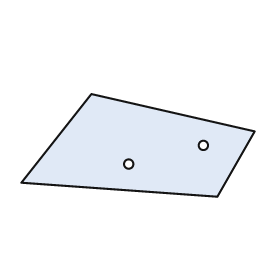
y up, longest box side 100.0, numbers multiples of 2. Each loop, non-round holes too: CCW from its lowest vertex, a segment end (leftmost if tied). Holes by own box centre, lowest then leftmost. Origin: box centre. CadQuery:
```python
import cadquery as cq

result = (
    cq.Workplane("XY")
    .moveTo(34.0, -22.0)
    .lineTo(50.0, 6.0)
    .lineTo(-20.0, 22.0)
    .lineTo(-50.0, -16.0)
    .close()
    .moveTo(-4.0, -8.0)
    .circle(2.0)
    .moveTo(28.0, 0.0)
    .circle(2.0)
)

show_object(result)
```